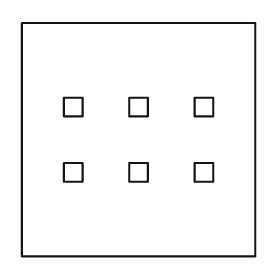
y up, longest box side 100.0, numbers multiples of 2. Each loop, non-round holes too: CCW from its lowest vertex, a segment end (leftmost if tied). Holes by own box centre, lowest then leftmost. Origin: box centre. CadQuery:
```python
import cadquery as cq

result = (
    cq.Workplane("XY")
    .moveTo(-50.0, -50.0)
    .lineTo(50.0, -50.0)
    .lineTo(50.0, 50.0)
    .lineTo(-50.0, 50.0)
    .close()
    .moveTo(-32.0, -18.0)
    .lineTo(-24.0, -18.0)
    .lineTo(-24.0, -10.0)
    .lineTo(-32.0, -10.0)
    .close()
    .moveTo(-4.0, -18.0)
    .lineTo(4.0, -18.0)
    .lineTo(4.0, -10.0)
    .lineTo(-4.0, -10.0)
    .close()
    .moveTo(24.0, -18.0)
    .lineTo(32.0, -18.0)
    .lineTo(32.0, -10.0)
    .lineTo(24.0, -10.0)
    .close()
    .moveTo(-32.0, 10.0)
    .lineTo(-24.0, 10.0)
    .lineTo(-24.0, 18.0)
    .lineTo(-32.0, 18.0)
    .close()
    .moveTo(-4.0, 10.0)
    .lineTo(4.0, 10.0)
    .lineTo(4.0, 18.0)
    .lineTo(-4.0, 18.0)
    .close()
    .moveTo(24.0, 10.0)
    .lineTo(32.0, 10.0)
    .lineTo(32.0, 18.0)
    .lineTo(24.0, 18.0)
    .close()
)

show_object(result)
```